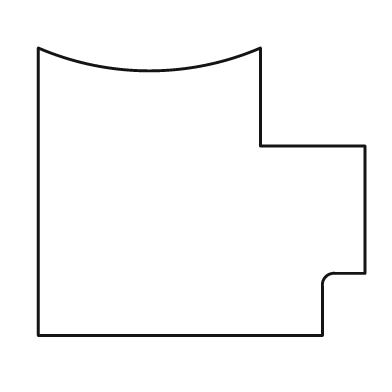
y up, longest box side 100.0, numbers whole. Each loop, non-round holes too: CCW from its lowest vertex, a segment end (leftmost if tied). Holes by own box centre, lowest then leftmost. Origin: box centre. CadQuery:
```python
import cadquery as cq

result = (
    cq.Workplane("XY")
    .moveTo(-50.0, -44.0)
    .lineTo(37.0, -44.0)
    .lineTo(37.0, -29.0)
    .threePointArc((38.0, -26.0), (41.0, -25.0))
    .lineTo(50.0, -25.0)
    .lineTo(50.0, 14.0)
    .lineTo(18.0, 14.0)
    .lineTo(18.0, 44.0)
    .threePointArc((-16.0, 37.0), (-50.0, 44.0))
    .close()
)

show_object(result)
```